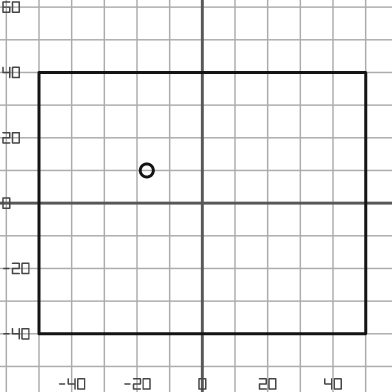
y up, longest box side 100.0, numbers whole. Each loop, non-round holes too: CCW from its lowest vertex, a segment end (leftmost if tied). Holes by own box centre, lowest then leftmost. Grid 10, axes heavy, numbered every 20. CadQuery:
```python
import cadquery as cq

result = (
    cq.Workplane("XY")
    .moveTo(-50.0, -40.0)
    .lineTo(50.0, -40.0)
    .lineTo(50.0, 40.0)
    .lineTo(-50.0, 40.0)
    .close()
    .moveTo(-17.0, 10.0)
    .circle(2.0)
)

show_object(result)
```